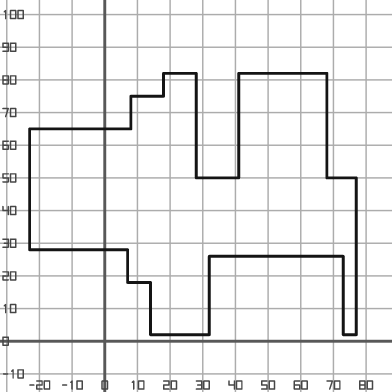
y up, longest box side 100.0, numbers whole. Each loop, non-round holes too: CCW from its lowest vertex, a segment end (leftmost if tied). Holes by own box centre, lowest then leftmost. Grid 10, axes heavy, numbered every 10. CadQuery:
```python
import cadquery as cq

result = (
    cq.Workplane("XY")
    .moveTo(14.0, 2.0)
    .lineTo(32.0, 2.0)
    .lineTo(32.0, 26.0)
    .lineTo(73.0, 26.0)
    .lineTo(73.0, 2.0)
    .lineTo(77.0, 2.0)
    .lineTo(77.0, 50.0)
    .lineTo(68.0, 50.0)
    .lineTo(68.0, 82.0)
    .lineTo(41.0, 82.0)
    .lineTo(41.0, 50.0)
    .lineTo(28.0, 50.0)
    .lineTo(28.0, 82.0)
    .lineTo(18.0, 82.0)
    .lineTo(18.0, 75.0)
    .lineTo(8.0, 75.0)
    .lineTo(8.0, 65.0)
    .lineTo(-23.0, 65.0)
    .lineTo(-23.0, 28.0)
    .lineTo(7.0, 28.0)
    .lineTo(7.0, 18.0)
    .lineTo(14.0, 18.0)
    .close()
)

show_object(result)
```